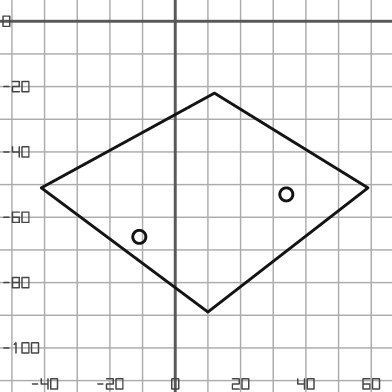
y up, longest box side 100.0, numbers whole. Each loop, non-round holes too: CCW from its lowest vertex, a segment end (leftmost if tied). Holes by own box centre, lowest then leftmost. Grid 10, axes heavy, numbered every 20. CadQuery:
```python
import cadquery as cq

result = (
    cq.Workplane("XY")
    .moveTo(10.0, -89.0)
    .lineTo(59.0, -51.0)
    .lineTo(12.0, -22.0)
    .lineTo(-41.0, -51.0)
    .close()
    .moveTo(-11.0, -66.0)
    .circle(2.0)
    .moveTo(34.0, -53.0)
    .circle(2.0)
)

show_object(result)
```